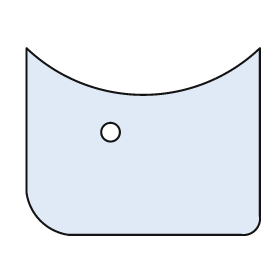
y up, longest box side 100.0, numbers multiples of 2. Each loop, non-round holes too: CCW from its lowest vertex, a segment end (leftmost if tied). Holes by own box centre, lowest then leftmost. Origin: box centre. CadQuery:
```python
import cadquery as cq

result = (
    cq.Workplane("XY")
    .moveTo(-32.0, -40.0)
    .lineTo(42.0, -40.0)
    .threePointArc((48.0, -38.0), (50.0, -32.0))
    .lineTo(50.0, 40.0)
    .threePointArc((0.0, 20.0), (-50.0, 40.0))
    .lineTo(-50.0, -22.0)
    .threePointArc((-44.0, -34.0), (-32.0, -40.0))
    .close()
    .moveTo(-14.0, 4.0)
    .circle(4.0)
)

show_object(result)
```